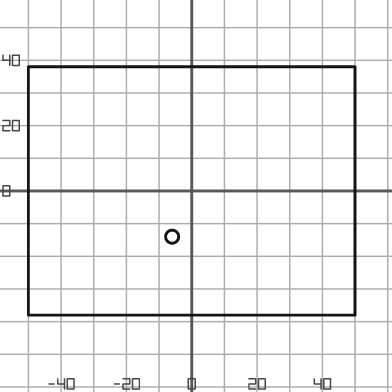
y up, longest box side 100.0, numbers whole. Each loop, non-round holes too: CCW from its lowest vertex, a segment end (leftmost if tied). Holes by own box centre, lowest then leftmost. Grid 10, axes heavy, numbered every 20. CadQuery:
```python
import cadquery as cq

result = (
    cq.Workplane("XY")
    .moveTo(-50.0, -38.0)
    .lineTo(50.0, -38.0)
    .lineTo(50.0, 38.0)
    .lineTo(-50.0, 38.0)
    .close()
    .moveTo(-6.0, -14.0)
    .circle(2.0)
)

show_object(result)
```